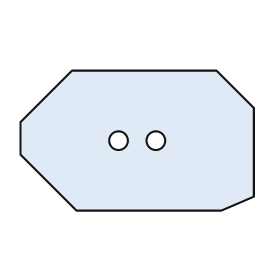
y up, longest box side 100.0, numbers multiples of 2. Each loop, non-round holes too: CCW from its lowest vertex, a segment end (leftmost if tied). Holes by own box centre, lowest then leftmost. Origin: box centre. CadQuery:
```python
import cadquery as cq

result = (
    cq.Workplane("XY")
    .moveTo(-26.0, -30.0)
    .lineTo(36.0, -30.0)
    .lineTo(50.0, -24.0)
    .lineTo(50.0, 14.0)
    .lineTo(34.0, 30.0)
    .lineTo(-28.0, 30.0)
    .lineTo(-50.0, 8.0)
    .lineTo(-50.0, -6.0)
    .close()
    .moveTo(-8.0, 0.0)
    .circle(4.0)
    .moveTo(8.0, 0.0)
    .circle(4.0)
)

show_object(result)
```